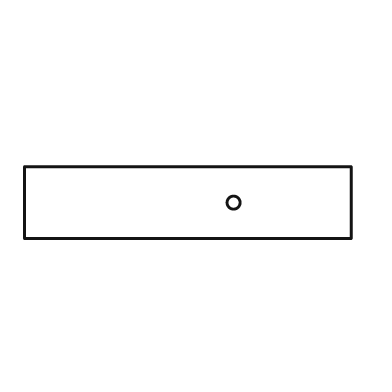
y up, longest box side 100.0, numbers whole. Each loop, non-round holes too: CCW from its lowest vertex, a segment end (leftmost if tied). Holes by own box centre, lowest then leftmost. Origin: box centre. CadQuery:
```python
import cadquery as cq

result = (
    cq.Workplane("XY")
    .moveTo(-50.0, -11.0)
    .lineTo(50.0, -11.0)
    .lineTo(50.0, 11.0)
    .lineTo(-50.0, 11.0)
    .close()
    .moveTo(14.0, 0.0)
    .circle(2.0)
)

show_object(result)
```